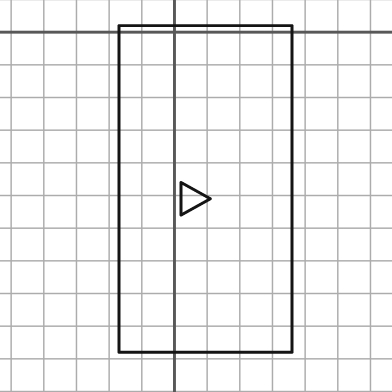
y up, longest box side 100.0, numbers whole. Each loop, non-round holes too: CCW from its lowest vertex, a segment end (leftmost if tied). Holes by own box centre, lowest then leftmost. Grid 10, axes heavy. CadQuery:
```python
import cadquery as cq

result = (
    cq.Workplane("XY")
    .moveTo(-17.0, -98.0)
    .lineTo(36.0, -98.0)
    .lineTo(36.0, 2.0)
    .lineTo(-17.0, 2.0)
    .close()
    .moveTo(2.0, -56.0)
    .lineTo(11.0, -51.0)
    .lineTo(2.0, -46.0)
    .close()
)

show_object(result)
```